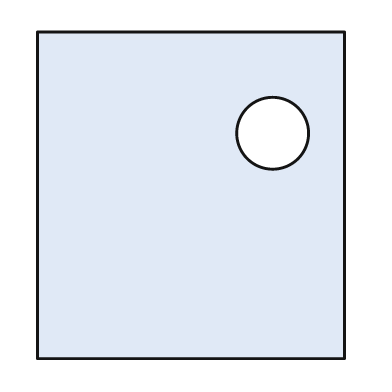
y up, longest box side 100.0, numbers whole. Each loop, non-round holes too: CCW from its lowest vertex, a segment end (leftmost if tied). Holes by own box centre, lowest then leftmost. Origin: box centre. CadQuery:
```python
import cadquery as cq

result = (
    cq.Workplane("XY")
    .moveTo(-47.0, -50.0)
    .lineTo(47.0, -50.0)
    .lineTo(47.0, 50.0)
    .lineTo(-47.0, 50.0)
    .close()
    .moveTo(25.0, 19.0)
    .circle(11.0)
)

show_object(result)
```